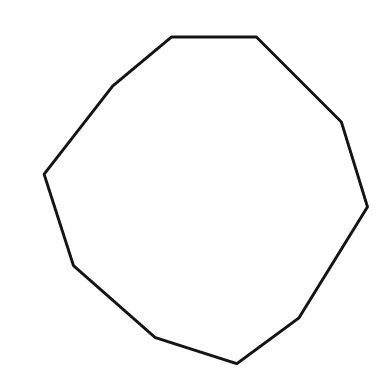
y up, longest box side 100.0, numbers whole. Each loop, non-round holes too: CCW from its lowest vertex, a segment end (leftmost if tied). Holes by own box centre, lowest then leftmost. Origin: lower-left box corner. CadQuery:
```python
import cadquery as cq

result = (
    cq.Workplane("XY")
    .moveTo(59.0, 0.0)
    .lineTo(78.0, 14.0)
    .lineTo(99.0, 48.0)
    .lineTo(91.0, 74.0)
    .lineTo(65.0, 100.0)
    .lineTo(39.0, 100.0)
    .lineTo(21.0, 85.0)
    .lineTo(0.0, 58.0)
    .lineTo(9.0, 30.0)
    .lineTo(34.0, 8.0)
    .close()
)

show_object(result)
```